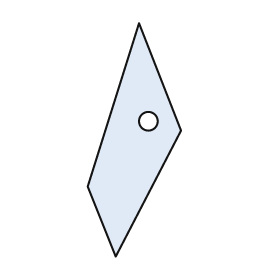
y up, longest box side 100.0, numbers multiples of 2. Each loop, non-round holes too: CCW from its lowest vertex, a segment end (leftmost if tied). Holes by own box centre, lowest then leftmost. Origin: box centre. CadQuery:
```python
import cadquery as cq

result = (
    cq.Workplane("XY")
    .moveTo(-8.0, -50.0)
    .lineTo(20.0, 4.0)
    .lineTo(2.0, 50.0)
    .lineTo(-20.0, -20.0)
    .close()
    .moveTo(6.0, 8.0)
    .circle(4.0)
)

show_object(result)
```